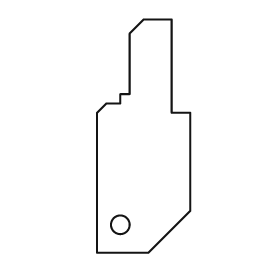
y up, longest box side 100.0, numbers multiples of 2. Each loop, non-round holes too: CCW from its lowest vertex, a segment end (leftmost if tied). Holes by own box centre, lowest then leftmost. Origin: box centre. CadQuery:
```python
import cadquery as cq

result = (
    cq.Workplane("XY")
    .moveTo(-20.0, -50.0)
    .lineTo(2.0, -50.0)
    .lineTo(20.0, -32.0)
    .lineTo(20.0, 10.0)
    .lineTo(12.0, 10.0)
    .lineTo(12.0, 50.0)
    .lineTo(0.0, 50.0)
    .lineTo(-6.0, 44.0)
    .lineTo(-6.0, 18.0)
    .lineTo(-10.0, 18.0)
    .lineTo(-10.0, 14.0)
    .lineTo(-16.0, 14.0)
    .lineTo(-20.0, 10.0)
    .close()
    .moveTo(-10.0, -38.0)
    .circle(4.0)
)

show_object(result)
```